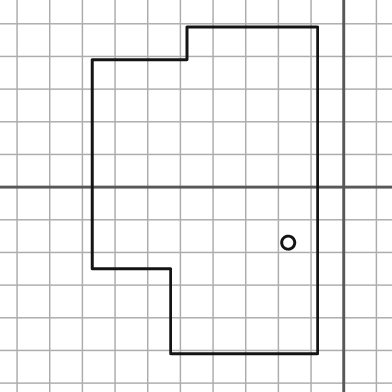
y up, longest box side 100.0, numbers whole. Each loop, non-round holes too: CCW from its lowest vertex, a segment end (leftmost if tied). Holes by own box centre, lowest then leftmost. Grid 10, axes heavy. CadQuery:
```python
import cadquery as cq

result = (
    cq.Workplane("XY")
    .moveTo(-53.0, -51.0)
    .lineTo(-8.0, -51.0)
    .lineTo(-8.0, 49.0)
    .lineTo(-48.0, 49.0)
    .lineTo(-48.0, 39.0)
    .lineTo(-77.0, 39.0)
    .lineTo(-77.0, -25.0)
    .lineTo(-53.0, -25.0)
    .close()
    .moveTo(-17.0, -17.0)
    .circle(2.0)
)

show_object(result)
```